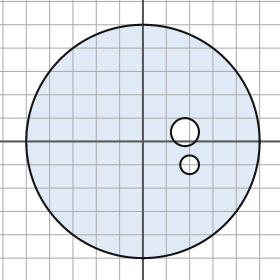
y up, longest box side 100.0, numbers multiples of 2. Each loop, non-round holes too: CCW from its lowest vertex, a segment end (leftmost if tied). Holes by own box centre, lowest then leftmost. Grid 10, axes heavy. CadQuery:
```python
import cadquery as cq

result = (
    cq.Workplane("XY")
    .moveTo(0.0, 0.0)
    .circle(50.0)
    .moveTo(20.0, -10.0)
    .circle(4.0)
    .moveTo(18.0, 4.0)
    .circle(6.0)
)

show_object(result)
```